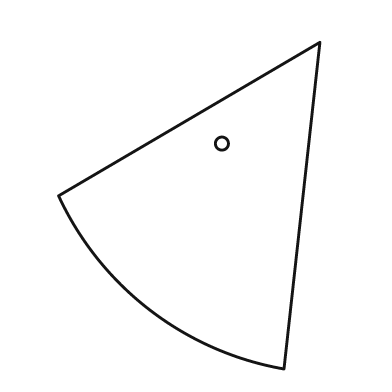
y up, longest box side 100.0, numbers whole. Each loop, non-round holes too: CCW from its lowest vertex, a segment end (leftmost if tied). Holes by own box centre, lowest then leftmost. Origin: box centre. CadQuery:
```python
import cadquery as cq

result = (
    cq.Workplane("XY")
    .moveTo(29.0, -50.0)
    .lineTo(40.0, 50.0)
    .lineTo(-40.0, 3.0)
    .threePointArc((-12.0, -32.0), (29.0, -50.0))
    .close()
    .moveTo(10.0, 19.0)
    .circle(2.0)
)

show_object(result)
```